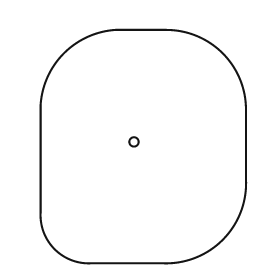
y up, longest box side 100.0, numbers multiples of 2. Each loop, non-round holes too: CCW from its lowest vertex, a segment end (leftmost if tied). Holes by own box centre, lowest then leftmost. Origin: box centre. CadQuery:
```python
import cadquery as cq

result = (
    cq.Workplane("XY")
    .moveTo(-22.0, -50.0)
    .lineTo(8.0, -50.0)
    .threePointArc((34.0, -40.0), (44.0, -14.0))
    .lineTo(44.0, 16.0)
    .threePointArc((34.0, 40.0), (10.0, 50.0))
    .lineTo(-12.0, 50.0)
    .threePointArc((-34.0, 40.0), (-44.0, 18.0))
    .lineTo(-44.0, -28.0)
    .threePointArc((-38.0, -44.0), (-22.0, -50.0))
    .close()
    .moveTo(-4.0, 2.0)
    .circle(2.0)
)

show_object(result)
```